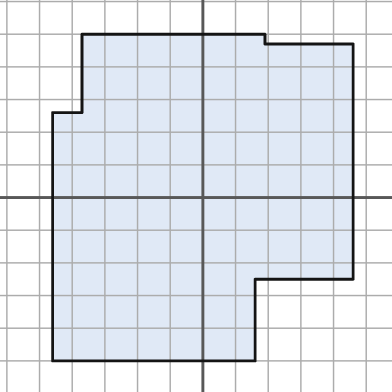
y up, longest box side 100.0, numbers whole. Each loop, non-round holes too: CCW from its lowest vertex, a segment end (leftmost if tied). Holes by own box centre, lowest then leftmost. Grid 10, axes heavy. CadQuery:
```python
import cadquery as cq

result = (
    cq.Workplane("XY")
    .moveTo(-46.0, -50.0)
    .lineTo(16.0, -50.0)
    .lineTo(16.0, -25.0)
    .lineTo(46.0, -25.0)
    .lineTo(46.0, 47.0)
    .lineTo(19.0, 47.0)
    .lineTo(19.0, 50.0)
    .lineTo(-37.0, 50.0)
    .lineTo(-37.0, 26.0)
    .lineTo(-46.0, 26.0)
    .close()
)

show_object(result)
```